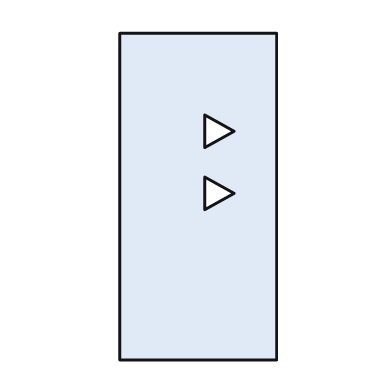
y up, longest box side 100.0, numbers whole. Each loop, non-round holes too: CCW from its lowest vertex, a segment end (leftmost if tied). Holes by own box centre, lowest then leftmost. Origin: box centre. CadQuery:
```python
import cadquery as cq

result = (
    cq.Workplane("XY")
    .moveTo(-24.0, -50.0)
    .lineTo(24.0, -50.0)
    .lineTo(24.0, 50.0)
    .lineTo(-24.0, 50.0)
    .close()
    .moveTo(2.0, -4.0)
    .lineTo(11.0, 1.0)
    .lineTo(2.0, 6.0)
    .close()
    .moveTo(2.0, 15.0)
    .lineTo(11.0, 20.0)
    .lineTo(2.0, 25.0)
    .close()
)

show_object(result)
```